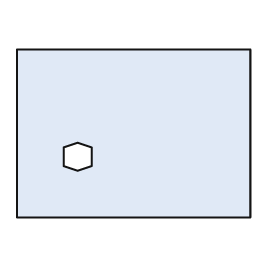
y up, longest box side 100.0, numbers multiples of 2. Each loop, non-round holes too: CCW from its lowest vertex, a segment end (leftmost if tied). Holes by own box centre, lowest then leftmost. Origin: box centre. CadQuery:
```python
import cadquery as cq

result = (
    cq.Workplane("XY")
    .moveTo(-50.0, -36.0)
    .lineTo(50.0, -36.0)
    .lineTo(50.0, 36.0)
    .lineTo(-50.0, 36.0)
    .close()
    .moveTo(-24.0, -16.0)
    .lineTo(-18.0, -14.0)
    .lineTo(-18.0, -6.0)
    .lineTo(-24.0, -4.0)
    .lineTo(-30.0, -6.0)
    .lineTo(-30.0, -14.0)
    .close()
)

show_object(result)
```